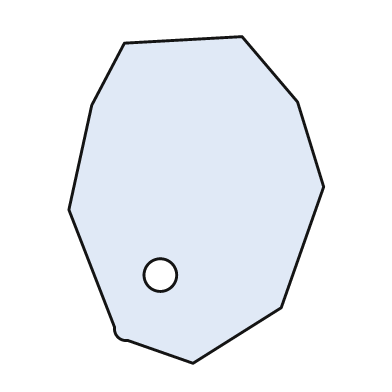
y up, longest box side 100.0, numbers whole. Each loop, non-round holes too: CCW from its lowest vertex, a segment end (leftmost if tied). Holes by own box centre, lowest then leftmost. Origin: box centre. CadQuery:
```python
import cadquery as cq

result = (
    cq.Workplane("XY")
    .moveTo(-1.0, -50.0)
    .lineTo(26.0, -33.0)
    .lineTo(39.0, 4.0)
    .lineTo(31.0, 30.0)
    .lineTo(14.0, 50.0)
    .lineTo(-22.0, 48.0)
    .lineTo(-32.0, 29.0)
    .lineTo(-39.0, -3.0)
    .lineTo(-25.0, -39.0)
    .threePointArc((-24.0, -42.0), (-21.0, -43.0))
    .close()
    .moveTo(-11.0, -23.0)
    .circle(5.0)
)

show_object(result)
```